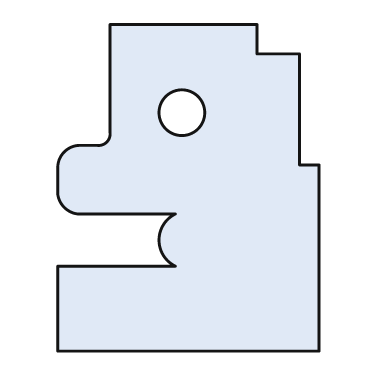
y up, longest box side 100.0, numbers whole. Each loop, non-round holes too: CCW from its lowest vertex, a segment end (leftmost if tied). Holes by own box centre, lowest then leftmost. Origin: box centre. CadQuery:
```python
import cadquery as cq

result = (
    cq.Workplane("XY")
    .moveTo(-40.0, -50.0)
    .lineTo(40.0, -50.0)
    .lineTo(40.0, 7.0)
    .lineTo(34.0, 7.0)
    .lineTo(34.0, 41.0)
    .lineTo(21.0, 41.0)
    .lineTo(21.0, 50.0)
    .lineTo(-24.0, 50.0)
    .lineTo(-24.0, 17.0)
    .threePointArc((-25.0, 14.0), (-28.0, 13.0))
    .lineTo(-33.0, 13.0)
    .threePointArc((-38.0, 11.0), (-40.0, 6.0))
    .lineTo(-40.0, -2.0)
    .threePointArc((-38.0, -6.0), (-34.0, -8.0))
    .lineTo(-4.0, -8.0)
    .threePointArc((-9.0, -16.0), (-4.0, -24.0))
    .lineTo(-40.0, -24.0)
    .close()
    .moveTo(-2.0, 23.0)
    .circle(7.0)
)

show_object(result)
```